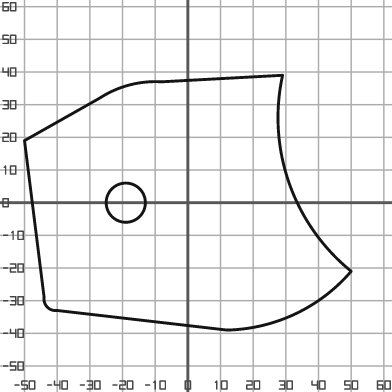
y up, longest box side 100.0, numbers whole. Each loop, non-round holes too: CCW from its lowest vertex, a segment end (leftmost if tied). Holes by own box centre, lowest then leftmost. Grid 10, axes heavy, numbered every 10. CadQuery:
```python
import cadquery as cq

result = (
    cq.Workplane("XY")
    .moveTo(12.0, -39.0)
    .threePointArc((33.0, -34.0), (50.0, -21.0))
    .threePointArc((31.0, 6.0), (29.0, 39.0))
    .lineTo(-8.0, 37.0)
    .threePointArc((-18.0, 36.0), (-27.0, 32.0))
    .lineTo(-50.0, 19.0)
    .lineTo(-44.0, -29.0)
    .threePointArc((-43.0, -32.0), (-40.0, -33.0))
    .close()
    .moveTo(-19.0, 0.0)
    .circle(6.0)
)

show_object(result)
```